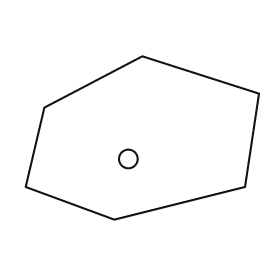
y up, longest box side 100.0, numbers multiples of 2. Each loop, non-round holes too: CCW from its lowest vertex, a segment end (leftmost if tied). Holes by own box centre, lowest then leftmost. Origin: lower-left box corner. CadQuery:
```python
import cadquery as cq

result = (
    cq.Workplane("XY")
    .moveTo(38.0, 0.0)
    .lineTo(94.0, 14.0)
    .lineTo(100.0, 54.0)
    .lineTo(50.0, 70.0)
    .lineTo(8.0, 48.0)
    .lineTo(0.0, 14.0)
    .close()
    .moveTo(44.0, 26.0)
    .circle(4.0)
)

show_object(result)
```